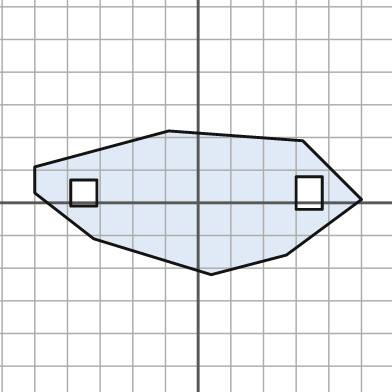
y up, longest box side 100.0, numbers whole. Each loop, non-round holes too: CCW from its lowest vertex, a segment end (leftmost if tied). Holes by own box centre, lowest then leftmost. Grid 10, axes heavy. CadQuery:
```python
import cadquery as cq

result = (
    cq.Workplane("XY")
    .moveTo(4.0, -22.0)
    .lineTo(27.0, -16.0)
    .lineTo(50.0, 1.0)
    .lineTo(32.0, 19.0)
    .lineTo(-9.0, 22.0)
    .lineTo(-50.0, 11.0)
    .lineTo(-50.0, 3.0)
    .lineTo(-32.0, -11.0)
    .close()
    .moveTo(-39.0, -1.0)
    .lineTo(-31.0, -1.0)
    .lineTo(-31.0, 7.0)
    .lineTo(-39.0, 7.0)
    .close()
    .moveTo(30.0, -2.0)
    .lineTo(38.0, -2.0)
    .lineTo(38.0, 8.0)
    .lineTo(30.0, 8.0)
    .close()
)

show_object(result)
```